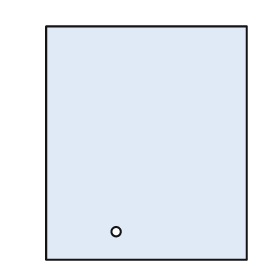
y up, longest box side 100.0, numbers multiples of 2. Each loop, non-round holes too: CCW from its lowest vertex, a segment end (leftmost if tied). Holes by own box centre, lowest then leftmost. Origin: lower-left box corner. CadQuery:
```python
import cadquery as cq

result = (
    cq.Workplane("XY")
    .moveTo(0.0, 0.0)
    .lineTo(86.0, 0.0)
    .lineTo(86.0, 100.0)
    .lineTo(0.0, 100.0)
    .close()
    .moveTo(30.0, 12.0)
    .circle(2.0)
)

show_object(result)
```